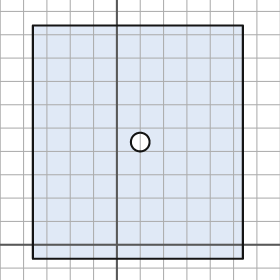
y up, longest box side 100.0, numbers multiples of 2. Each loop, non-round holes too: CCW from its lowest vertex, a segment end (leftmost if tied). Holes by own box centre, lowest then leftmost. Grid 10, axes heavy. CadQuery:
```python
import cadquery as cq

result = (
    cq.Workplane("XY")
    .moveTo(-36.0, -6.0)
    .lineTo(54.0, -6.0)
    .lineTo(54.0, 94.0)
    .lineTo(-36.0, 94.0)
    .close()
    .moveTo(10.0, 44.0)
    .circle(4.0)
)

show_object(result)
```